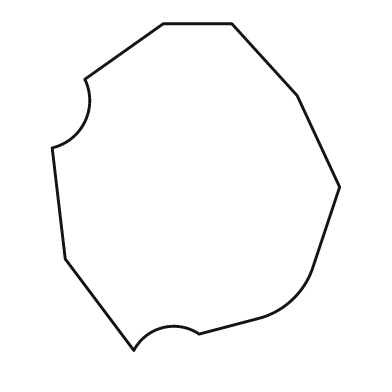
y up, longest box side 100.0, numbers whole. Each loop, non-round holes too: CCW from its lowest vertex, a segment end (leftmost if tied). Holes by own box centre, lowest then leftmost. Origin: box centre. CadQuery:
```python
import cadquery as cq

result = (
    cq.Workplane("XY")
    .moveTo(-19.0, -50.0)
    .threePointArc((-10.0, -43.0), (1.0, -45.0))
    .lineTo(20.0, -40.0)
    .threePointArc((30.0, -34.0), (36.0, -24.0))
    .lineTo(44.0, 0.0)
    .lineTo(31.0, 28.0)
    .lineTo(11.0, 50.0)
    .lineTo(-10.0, 50.0)
    .lineTo(-34.0, 33.0)
    .threePointArc((-34.0, 20.0), (-44.0, 12.0))
    .lineTo(-40.0, -22.0)
    .close()
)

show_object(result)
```